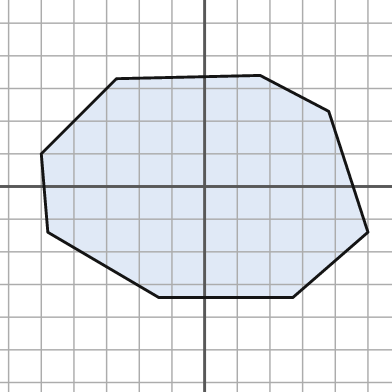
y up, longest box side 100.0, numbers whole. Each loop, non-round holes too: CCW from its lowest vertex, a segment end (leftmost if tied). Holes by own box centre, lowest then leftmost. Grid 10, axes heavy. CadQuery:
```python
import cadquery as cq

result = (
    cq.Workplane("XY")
    .moveTo(-14.0, -34.0)
    .lineTo(27.0, -34.0)
    .lineTo(50.0, -14.0)
    .lineTo(38.0, 23.0)
    .lineTo(17.0, 34.0)
    .lineTo(-27.0, 33.0)
    .lineTo(-50.0, 10.0)
    .lineTo(-48.0, -14.0)
    .close()
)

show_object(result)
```